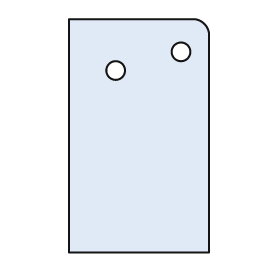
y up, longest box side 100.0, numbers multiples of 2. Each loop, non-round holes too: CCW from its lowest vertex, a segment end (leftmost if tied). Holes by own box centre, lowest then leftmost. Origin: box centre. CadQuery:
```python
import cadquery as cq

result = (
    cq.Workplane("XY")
    .moveTo(-30.0, -50.0)
    .lineTo(30.0, -50.0)
    .lineTo(30.0, 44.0)
    .threePointArc((28.0, 48.0), (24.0, 50.0))
    .lineTo(-30.0, 50.0)
    .close()
    .moveTo(-10.0, 28.0)
    .circle(4.0)
    .moveTo(18.0, 36.0)
    .circle(4.0)
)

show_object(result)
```